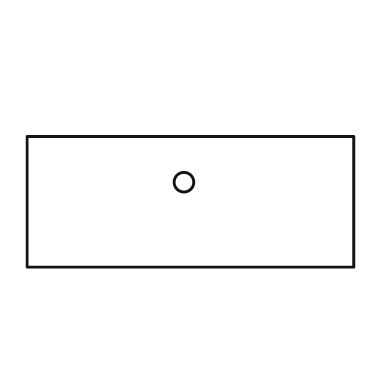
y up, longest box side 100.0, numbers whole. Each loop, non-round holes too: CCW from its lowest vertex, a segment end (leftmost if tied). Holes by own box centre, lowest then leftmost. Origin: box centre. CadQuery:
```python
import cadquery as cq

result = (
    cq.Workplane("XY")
    .moveTo(-50.0, -20.0)
    .lineTo(50.0, -20.0)
    .lineTo(50.0, 20.0)
    .lineTo(-50.0, 20.0)
    .close()
    .moveTo(-2.0, 6.0)
    .circle(3.0)
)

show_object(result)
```